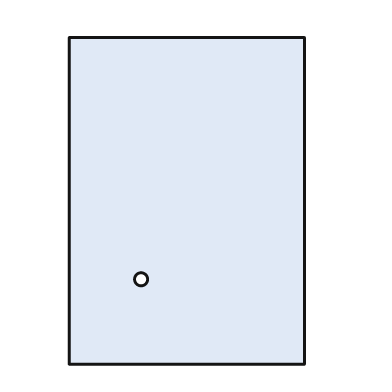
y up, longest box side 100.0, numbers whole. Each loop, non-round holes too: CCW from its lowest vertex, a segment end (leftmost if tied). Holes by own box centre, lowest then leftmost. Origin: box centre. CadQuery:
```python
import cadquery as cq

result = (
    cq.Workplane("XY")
    .moveTo(-36.0, -50.0)
    .lineTo(36.0, -50.0)
    .lineTo(36.0, 50.0)
    .lineTo(-36.0, 50.0)
    .close()
    .moveTo(-14.0, -24.0)
    .circle(2.0)
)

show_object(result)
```